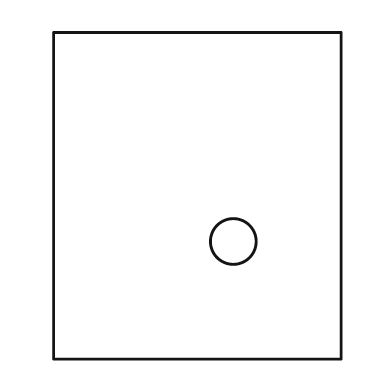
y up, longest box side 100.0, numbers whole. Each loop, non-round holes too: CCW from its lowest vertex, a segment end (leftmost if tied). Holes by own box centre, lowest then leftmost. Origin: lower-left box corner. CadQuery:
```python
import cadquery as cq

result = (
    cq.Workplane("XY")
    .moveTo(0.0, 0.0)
    .lineTo(88.0, 0.0)
    .lineTo(88.0, 100.0)
    .lineTo(0.0, 100.0)
    .close()
    .moveTo(55.0, 36.0)
    .circle(7.0)
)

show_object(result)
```